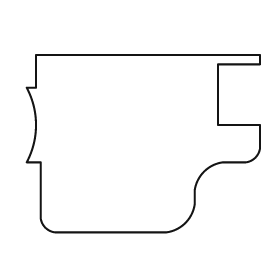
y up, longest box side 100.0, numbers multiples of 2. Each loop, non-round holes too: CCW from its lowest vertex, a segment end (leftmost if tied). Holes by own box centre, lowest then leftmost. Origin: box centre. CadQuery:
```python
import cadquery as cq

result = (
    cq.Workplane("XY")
    .moveTo(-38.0, -38.0)
    .lineTo(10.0, -38.0)
    .threePointArc((18.0, -34.0), (22.0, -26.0))
    .lineTo(22.0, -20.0)
    .threePointArc((26.0, -12.0), (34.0, -8.0))
    .lineTo(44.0, -8.0)
    .threePointArc((48.0, -6.0), (50.0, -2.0))
    .lineTo(50.0, 8.0)
    .lineTo(32.0, 8.0)
    .lineTo(32.0, 34.0)
    .lineTo(50.0, 34.0)
    .lineTo(50.0, 38.0)
    .lineTo(-46.0, 38.0)
    .lineTo(-46.0, 24.0)
    .lineTo(-50.0, 24.0)
    .threePointArc((-46.0, 8.0), (-50.0, -8.0))
    .lineTo(-44.0, -8.0)
    .lineTo(-44.0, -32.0)
    .threePointArc((-42.0, -36.0), (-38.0, -38.0))
    .close()
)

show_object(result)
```